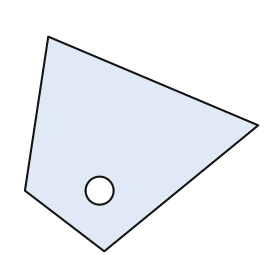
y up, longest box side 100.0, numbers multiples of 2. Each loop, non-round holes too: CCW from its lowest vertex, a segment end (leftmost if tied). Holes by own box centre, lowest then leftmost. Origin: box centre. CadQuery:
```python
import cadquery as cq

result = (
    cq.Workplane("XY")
    .moveTo(-16.0, -46.0)
    .lineTo(50.0, 8.0)
    .lineTo(-40.0, 46.0)
    .lineTo(-50.0, -20.0)
    .close()
    .moveTo(-18.0, -20.0)
    .circle(6.0)
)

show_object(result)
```